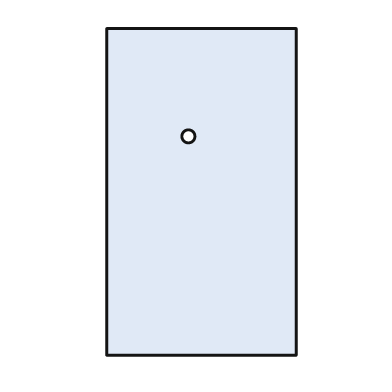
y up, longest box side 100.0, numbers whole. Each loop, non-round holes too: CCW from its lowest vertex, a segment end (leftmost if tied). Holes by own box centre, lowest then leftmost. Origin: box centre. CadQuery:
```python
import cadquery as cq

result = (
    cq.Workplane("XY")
    .moveTo(-29.0, -50.0)
    .lineTo(29.0, -50.0)
    .lineTo(29.0, 50.0)
    .lineTo(-29.0, 50.0)
    .close()
    .moveTo(-4.0, 17.0)
    .circle(2.0)
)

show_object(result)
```